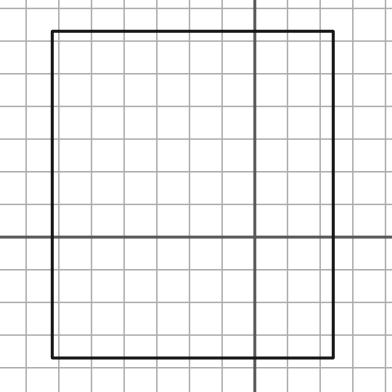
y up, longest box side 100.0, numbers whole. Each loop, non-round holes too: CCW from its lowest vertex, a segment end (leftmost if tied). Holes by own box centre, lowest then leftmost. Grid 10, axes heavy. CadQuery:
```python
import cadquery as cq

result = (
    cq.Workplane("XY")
    .moveTo(-62.0, -37.0)
    .lineTo(24.0, -37.0)
    .lineTo(24.0, 63.0)
    .lineTo(-62.0, 63.0)
    .close()
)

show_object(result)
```